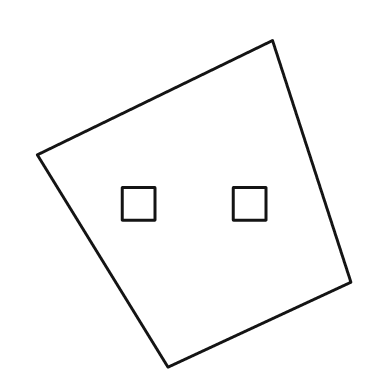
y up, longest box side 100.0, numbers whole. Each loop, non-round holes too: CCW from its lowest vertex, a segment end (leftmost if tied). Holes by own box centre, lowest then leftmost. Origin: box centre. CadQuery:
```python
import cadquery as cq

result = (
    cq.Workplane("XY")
    .moveTo(-8.0, -50.0)
    .lineTo(48.0, -24.0)
    .lineTo(24.0, 50.0)
    .lineTo(-48.0, 15.0)
    .close()
    .moveTo(-22.0, -5.0)
    .lineTo(-12.0, -5.0)
    .lineTo(-12.0, 5.0)
    .lineTo(-22.0, 5.0)
    .close()
    .moveTo(12.0, -5.0)
    .lineTo(22.0, -5.0)
    .lineTo(22.0, 5.0)
    .lineTo(12.0, 5.0)
    .close()
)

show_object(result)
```